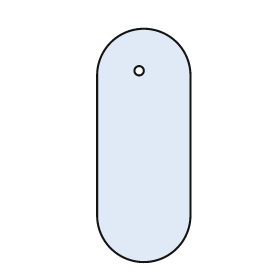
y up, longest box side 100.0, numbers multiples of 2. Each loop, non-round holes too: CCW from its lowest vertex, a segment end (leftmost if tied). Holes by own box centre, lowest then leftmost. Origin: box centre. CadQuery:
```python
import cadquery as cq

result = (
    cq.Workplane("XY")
    .moveTo(-20.0, -30.0)
    .threePointArc((0.0, -50.0), (20.0, -30.0))
    .lineTo(20.0, 30.0)
    .threePointArc((0.0, 50.0), (-20.0, 30.0))
    .close()
    .moveTo(-2.0, 32.0)
    .circle(2.0)
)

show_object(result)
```